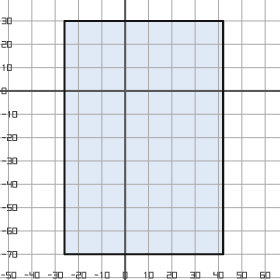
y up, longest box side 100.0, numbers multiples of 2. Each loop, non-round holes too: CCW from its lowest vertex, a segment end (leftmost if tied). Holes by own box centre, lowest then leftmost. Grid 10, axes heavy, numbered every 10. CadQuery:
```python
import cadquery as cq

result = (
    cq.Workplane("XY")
    .moveTo(-26.0, -70.0)
    .lineTo(42.0, -70.0)
    .lineTo(42.0, 30.0)
    .lineTo(-26.0, 30.0)
    .close()
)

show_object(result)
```